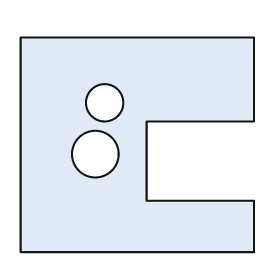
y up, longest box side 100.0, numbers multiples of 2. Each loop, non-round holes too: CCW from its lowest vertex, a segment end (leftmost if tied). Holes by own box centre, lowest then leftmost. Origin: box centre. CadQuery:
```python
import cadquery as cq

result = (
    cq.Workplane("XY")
    .moveTo(-50.0, -46.0)
    .lineTo(50.0, -46.0)
    .lineTo(50.0, -24.0)
    .lineTo(4.0, -24.0)
    .lineTo(4.0, 10.0)
    .lineTo(50.0, 10.0)
    .lineTo(50.0, 46.0)
    .lineTo(-50.0, 46.0)
    .close()
    .moveTo(-18.0, -4.0)
    .circle(10.0)
    .moveTo(-14.0, 18.0)
    .circle(8.0)
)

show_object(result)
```